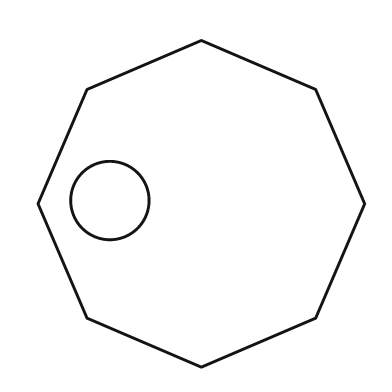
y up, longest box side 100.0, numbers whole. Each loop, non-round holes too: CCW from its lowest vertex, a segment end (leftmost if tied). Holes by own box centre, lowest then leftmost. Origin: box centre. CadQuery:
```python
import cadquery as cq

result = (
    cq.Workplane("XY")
    .moveTo(0.0, -50.0)
    .lineTo(35.0, -35.0)
    .lineTo(50.0, 0.0)
    .lineTo(35.0, 35.0)
    .lineTo(0.0, 50.0)
    .lineTo(-35.0, 35.0)
    .lineTo(-50.0, 0.0)
    .lineTo(-35.0, -35.0)
    .close()
    .moveTo(-28.0, 1.0)
    .circle(12.0)
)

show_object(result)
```